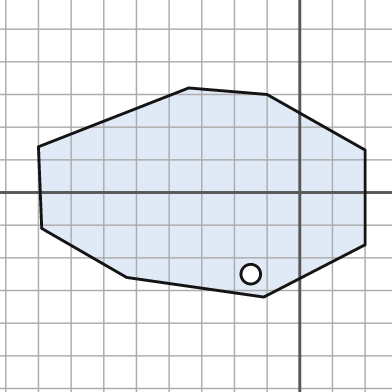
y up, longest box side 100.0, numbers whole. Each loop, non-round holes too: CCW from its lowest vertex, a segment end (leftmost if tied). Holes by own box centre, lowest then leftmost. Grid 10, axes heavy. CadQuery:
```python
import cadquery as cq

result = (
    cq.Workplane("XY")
    .moveTo(-11.0, -32.0)
    .lineTo(20.0, -16.0)
    .lineTo(20.0, 13.0)
    .lineTo(-10.0, 30.0)
    .lineTo(-34.0, 32.0)
    .lineTo(-80.0, 14.0)
    .lineTo(-79.0, -11.0)
    .lineTo(-53.0, -26.0)
    .close()
    .moveTo(-15.0, -25.0)
    .circle(3.0)
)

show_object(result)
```